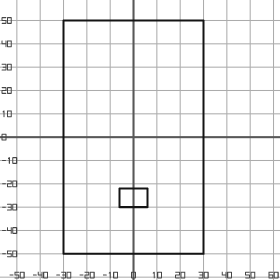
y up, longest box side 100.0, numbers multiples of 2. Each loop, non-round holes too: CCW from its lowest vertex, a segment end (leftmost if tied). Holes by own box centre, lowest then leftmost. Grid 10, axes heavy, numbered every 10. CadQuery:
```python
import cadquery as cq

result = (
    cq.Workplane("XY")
    .moveTo(-30.0, -50.0)
    .lineTo(30.0, -50.0)
    .lineTo(30.0, 50.0)
    .lineTo(-30.0, 50.0)
    .close()
    .moveTo(-6.0, -30.0)
    .lineTo(6.0, -30.0)
    .lineTo(6.0, -22.0)
    .lineTo(-6.0, -22.0)
    .close()
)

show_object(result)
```